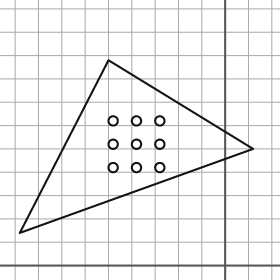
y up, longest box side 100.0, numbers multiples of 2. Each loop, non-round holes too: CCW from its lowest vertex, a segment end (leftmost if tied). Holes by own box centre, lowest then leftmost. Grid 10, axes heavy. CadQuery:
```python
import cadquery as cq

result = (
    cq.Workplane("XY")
    .moveTo(-88.0, 14.0)
    .lineTo(12.0, 50.0)
    .lineTo(-50.0, 88.0)
    .close()
    .moveTo(-48.0, 42.0)
    .circle(2.0)
    .moveTo(-38.0, 42.0)
    .circle(2.0)
    .moveTo(-28.0, 42.0)
    .circle(2.0)
    .moveTo(-48.0, 52.0)
    .circle(2.0)
    .moveTo(-38.0, 52.0)
    .circle(2.0)
    .moveTo(-28.0, 52.0)
    .circle(2.0)
    .moveTo(-48.0, 62.0)
    .circle(2.0)
    .moveTo(-38.0, 62.0)
    .circle(2.0)
    .moveTo(-28.0, 62.0)
    .circle(2.0)
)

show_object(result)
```